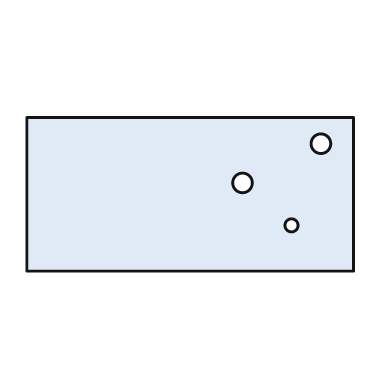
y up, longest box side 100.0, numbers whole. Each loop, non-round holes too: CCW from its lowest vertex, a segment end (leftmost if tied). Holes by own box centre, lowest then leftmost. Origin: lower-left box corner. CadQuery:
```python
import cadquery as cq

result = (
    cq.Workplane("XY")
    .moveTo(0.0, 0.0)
    .lineTo(100.0, 0.0)
    .lineTo(100.0, 47.0)
    .lineTo(0.0, 47.0)
    .close()
    .moveTo(81.0, 14.0)
    .circle(2.0)
    .moveTo(66.0, 27.0)
    .circle(3.0)
    .moveTo(90.0, 39.0)
    .circle(3.0)
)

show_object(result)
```